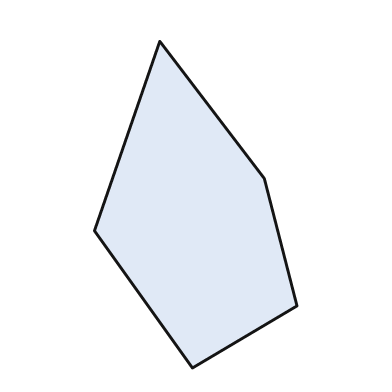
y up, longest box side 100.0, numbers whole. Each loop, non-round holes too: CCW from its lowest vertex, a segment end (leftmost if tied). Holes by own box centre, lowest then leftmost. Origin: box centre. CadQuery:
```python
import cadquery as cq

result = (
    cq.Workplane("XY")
    .moveTo(-1.0, -50.0)
    .lineTo(31.0, -31.0)
    .lineTo(21.0, 8.0)
    .lineTo(-11.0, 50.0)
    .lineTo(-31.0, -8.0)
    .close()
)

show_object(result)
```